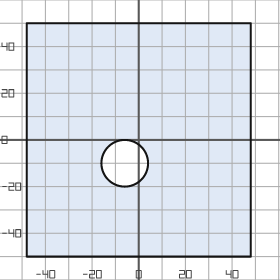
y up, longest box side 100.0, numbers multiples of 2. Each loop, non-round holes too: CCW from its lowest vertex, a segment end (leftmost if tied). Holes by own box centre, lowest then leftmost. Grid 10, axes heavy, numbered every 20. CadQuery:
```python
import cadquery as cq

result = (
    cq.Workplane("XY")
    .moveTo(-48.0, -50.0)
    .lineTo(48.0, -50.0)
    .lineTo(48.0, 50.0)
    .lineTo(-48.0, 50.0)
    .close()
    .moveTo(-6.0, -10.0)
    .circle(10.0)
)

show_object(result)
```